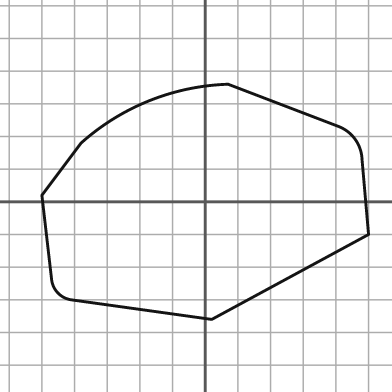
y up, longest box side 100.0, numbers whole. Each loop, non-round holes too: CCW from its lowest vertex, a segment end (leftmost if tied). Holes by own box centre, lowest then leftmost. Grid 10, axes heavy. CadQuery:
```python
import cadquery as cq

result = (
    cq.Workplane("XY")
    .moveTo(2.0, -36.0)
    .lineTo(50.0, -10.0)
    .lineTo(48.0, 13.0)
    .threePointArc((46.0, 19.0), (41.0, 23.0))
    .lineTo(7.0, 36.0)
    .threePointArc((-17.0, 31.0), (-38.0, 18.0))
    .lineTo(-50.0, 2.0)
    .lineTo(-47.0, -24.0)
    .threePointArc((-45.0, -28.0), (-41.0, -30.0))
    .close()
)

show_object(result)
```